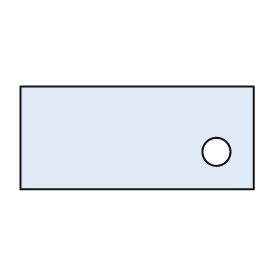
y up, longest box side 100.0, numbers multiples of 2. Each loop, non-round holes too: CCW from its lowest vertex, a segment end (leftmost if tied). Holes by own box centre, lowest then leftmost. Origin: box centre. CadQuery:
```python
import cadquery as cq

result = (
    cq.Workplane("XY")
    .moveTo(-50.0, -22.0)
    .lineTo(50.0, -22.0)
    .lineTo(50.0, 22.0)
    .lineTo(-50.0, 22.0)
    .close()
    .moveTo(34.0, -6.0)
    .circle(6.0)
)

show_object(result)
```